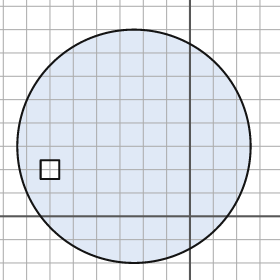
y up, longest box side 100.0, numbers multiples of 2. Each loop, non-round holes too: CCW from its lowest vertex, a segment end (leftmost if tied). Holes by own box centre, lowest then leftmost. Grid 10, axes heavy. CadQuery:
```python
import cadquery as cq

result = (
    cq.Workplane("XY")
    .moveTo(-24.0, 30.0)
    .circle(50.0)
    .moveTo(-64.0, 16.0)
    .lineTo(-56.0, 16.0)
    .lineTo(-56.0, 24.0)
    .lineTo(-64.0, 24.0)
    .close()
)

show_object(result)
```